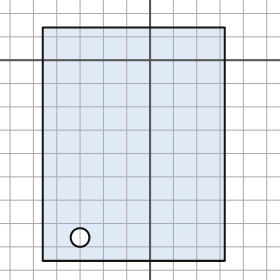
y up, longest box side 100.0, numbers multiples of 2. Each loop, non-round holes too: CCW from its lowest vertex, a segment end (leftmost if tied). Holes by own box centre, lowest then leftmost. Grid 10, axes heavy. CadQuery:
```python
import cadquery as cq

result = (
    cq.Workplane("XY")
    .moveTo(-46.0, -86.0)
    .lineTo(32.0, -86.0)
    .lineTo(32.0, 14.0)
    .lineTo(-46.0, 14.0)
    .close()
    .moveTo(-30.0, -76.0)
    .circle(4.0)
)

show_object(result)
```